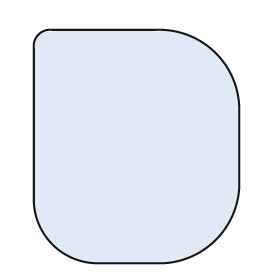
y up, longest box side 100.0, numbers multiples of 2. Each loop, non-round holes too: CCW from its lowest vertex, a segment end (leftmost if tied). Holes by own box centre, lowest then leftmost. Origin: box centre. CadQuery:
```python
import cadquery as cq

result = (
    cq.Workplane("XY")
    .moveTo(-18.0, -50.0)
    .lineTo(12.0, -50.0)
    .threePointArc((34.0, -40.0), (44.0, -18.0))
    .lineTo(44.0, 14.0)
    .threePointArc((34.0, 40.0), (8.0, 50.0))
    .lineTo(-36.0, 50.0)
    .threePointArc((-42.0, 48.0), (-44.0, 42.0))
    .lineTo(-44.0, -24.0)
    .threePointArc((-36.0, -42.0), (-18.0, -50.0))
    .close()
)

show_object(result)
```